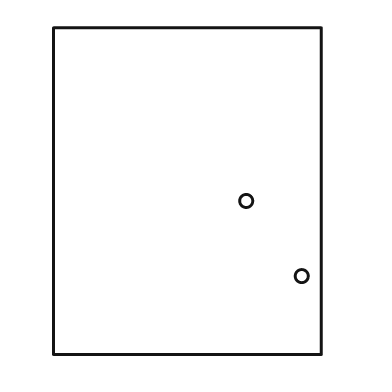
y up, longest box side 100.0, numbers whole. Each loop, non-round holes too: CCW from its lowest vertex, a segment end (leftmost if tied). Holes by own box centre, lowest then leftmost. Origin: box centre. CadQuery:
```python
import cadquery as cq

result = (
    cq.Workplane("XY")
    .moveTo(-41.0, -50.0)
    .lineTo(41.0, -50.0)
    .lineTo(41.0, 50.0)
    .lineTo(-41.0, 50.0)
    .close()
    .moveTo(35.0, -26.0)
    .circle(2.0)
    .moveTo(18.0, -3.0)
    .circle(2.0)
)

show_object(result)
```